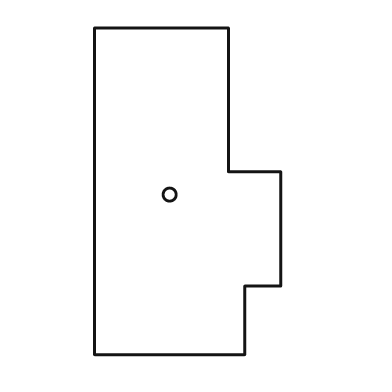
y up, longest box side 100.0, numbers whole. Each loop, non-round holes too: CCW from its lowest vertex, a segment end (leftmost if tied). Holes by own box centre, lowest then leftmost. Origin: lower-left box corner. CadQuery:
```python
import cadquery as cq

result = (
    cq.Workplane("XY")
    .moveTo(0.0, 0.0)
    .lineTo(46.0, 0.0)
    .lineTo(46.0, 21.0)
    .lineTo(57.0, 21.0)
    .lineTo(57.0, 56.0)
    .lineTo(41.0, 56.0)
    .lineTo(41.0, 100.0)
    .lineTo(0.0, 100.0)
    .close()
    .moveTo(23.0, 49.0)
    .circle(2.0)
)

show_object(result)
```